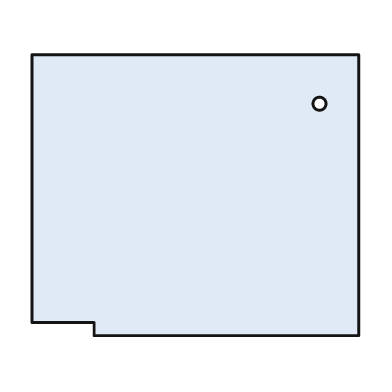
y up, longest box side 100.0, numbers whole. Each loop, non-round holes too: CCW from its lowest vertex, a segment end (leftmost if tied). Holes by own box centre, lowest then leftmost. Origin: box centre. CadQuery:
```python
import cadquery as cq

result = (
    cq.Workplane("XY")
    .moveTo(-31.0, -43.0)
    .lineTo(50.0, -43.0)
    .lineTo(50.0, 43.0)
    .lineTo(-50.0, 43.0)
    .lineTo(-50.0, -39.0)
    .lineTo(-31.0, -39.0)
    .close()
    .moveTo(38.0, 28.0)
    .circle(2.0)
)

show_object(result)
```